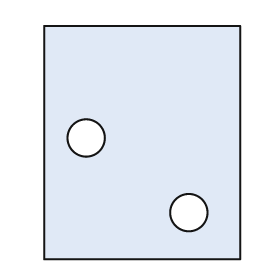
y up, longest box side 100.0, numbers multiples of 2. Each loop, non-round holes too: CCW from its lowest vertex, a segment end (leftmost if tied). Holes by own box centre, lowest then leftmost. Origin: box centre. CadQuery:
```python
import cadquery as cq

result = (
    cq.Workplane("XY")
    .moveTo(-42.0, -50.0)
    .lineTo(42.0, -50.0)
    .lineTo(42.0, 50.0)
    .lineTo(-42.0, 50.0)
    .close()
    .moveTo(20.0, -30.0)
    .circle(8.0)
    .moveTo(-24.0, 2.0)
    .circle(8.0)
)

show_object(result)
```